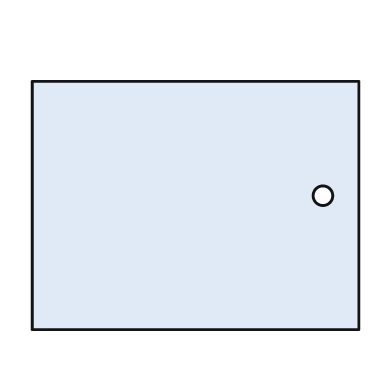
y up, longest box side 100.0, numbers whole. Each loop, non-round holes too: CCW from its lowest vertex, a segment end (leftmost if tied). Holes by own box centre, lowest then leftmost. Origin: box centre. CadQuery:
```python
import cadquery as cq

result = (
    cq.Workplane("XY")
    .moveTo(-50.0, -38.0)
    .lineTo(50.0, -38.0)
    .lineTo(50.0, 38.0)
    .lineTo(-50.0, 38.0)
    .close()
    .moveTo(39.0, 3.0)
    .circle(3.0)
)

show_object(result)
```